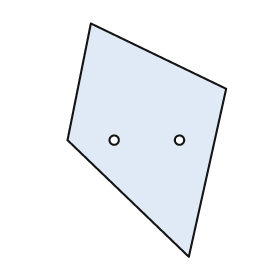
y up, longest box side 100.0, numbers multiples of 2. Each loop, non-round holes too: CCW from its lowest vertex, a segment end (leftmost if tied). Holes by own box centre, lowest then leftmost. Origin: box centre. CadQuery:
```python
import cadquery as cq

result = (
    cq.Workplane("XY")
    .moveTo(18.0, -50.0)
    .lineTo(34.0, 22.0)
    .lineTo(-24.0, 50.0)
    .lineTo(-34.0, 0.0)
    .close()
    .moveTo(-14.0, 0.0)
    .circle(2.0)
    .moveTo(14.0, 0.0)
    .circle(2.0)
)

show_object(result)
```